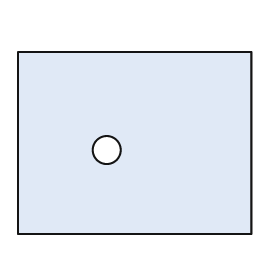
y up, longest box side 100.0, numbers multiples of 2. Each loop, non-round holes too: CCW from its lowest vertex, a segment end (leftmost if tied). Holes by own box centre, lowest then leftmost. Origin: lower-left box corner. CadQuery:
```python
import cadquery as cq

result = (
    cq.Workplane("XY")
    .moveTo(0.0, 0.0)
    .lineTo(100.0, 0.0)
    .lineTo(100.0, 78.0)
    .lineTo(0.0, 78.0)
    .close()
    .moveTo(38.0, 36.0)
    .circle(6.0)
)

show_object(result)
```